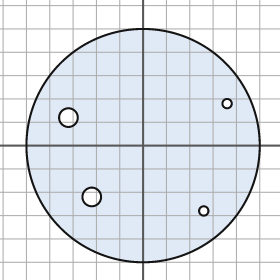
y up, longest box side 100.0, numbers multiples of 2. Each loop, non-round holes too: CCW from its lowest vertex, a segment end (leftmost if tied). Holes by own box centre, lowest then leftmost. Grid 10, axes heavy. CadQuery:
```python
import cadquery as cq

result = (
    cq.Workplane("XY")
    .moveTo(0.0, 0.0)
    .circle(50.0)
    .moveTo(26.0, -28.0)
    .circle(2.0)
    .moveTo(-22.0, -22.0)
    .circle(4.0)
    .moveTo(-32.0, 12.0)
    .circle(4.0)
    .moveTo(36.0, 18.0)
    .circle(2.0)
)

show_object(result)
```